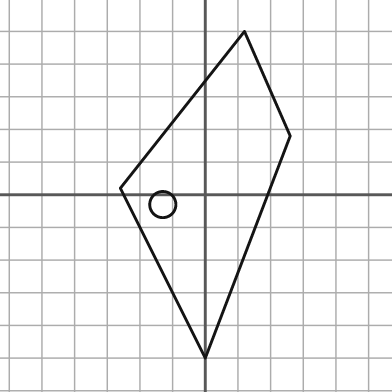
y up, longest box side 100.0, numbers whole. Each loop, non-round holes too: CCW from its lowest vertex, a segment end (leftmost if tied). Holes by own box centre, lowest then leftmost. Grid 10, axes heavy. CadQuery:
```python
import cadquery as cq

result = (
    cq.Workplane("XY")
    .moveTo(0.0, -50.0)
    .lineTo(26.0, 18.0)
    .lineTo(12.0, 50.0)
    .lineTo(-26.0, 2.0)
    .close()
    .moveTo(-13.0, -3.0)
    .circle(4.0)
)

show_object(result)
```